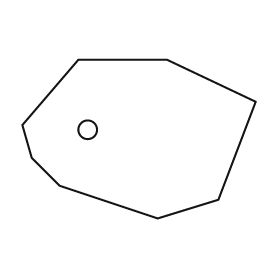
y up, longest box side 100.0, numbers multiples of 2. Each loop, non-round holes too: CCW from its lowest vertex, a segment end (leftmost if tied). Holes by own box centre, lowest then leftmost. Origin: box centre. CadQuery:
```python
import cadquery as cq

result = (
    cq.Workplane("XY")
    .moveTo(8.0, -34.0)
    .lineTo(34.0, -26.0)
    .lineTo(50.0, 16.0)
    .lineTo(12.0, 34.0)
    .lineTo(-26.0, 34.0)
    .lineTo(-50.0, 6.0)
    .lineTo(-46.0, -8.0)
    .lineTo(-34.0, -20.0)
    .close()
    .moveTo(-22.0, 4.0)
    .circle(4.0)
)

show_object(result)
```